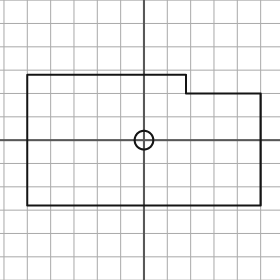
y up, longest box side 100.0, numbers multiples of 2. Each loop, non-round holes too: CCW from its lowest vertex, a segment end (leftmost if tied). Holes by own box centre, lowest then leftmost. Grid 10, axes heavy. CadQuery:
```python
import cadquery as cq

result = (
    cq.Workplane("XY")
    .moveTo(-50.0, -28.0)
    .lineTo(50.0, -28.0)
    .lineTo(50.0, 20.0)
    .lineTo(18.0, 20.0)
    .lineTo(18.0, 28.0)
    .lineTo(-50.0, 28.0)
    .close()
    .moveTo(0.0, 0.0)
    .circle(4.0)
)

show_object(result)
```